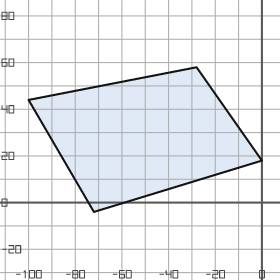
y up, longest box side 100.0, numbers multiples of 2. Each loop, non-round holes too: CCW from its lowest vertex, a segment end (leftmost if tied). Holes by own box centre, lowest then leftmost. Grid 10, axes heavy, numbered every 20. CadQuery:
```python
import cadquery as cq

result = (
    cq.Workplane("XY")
    .moveTo(-72.0, -4.0)
    .lineTo(0.0, 18.0)
    .lineTo(-28.0, 58.0)
    .lineTo(-100.0, 44.0)
    .close()
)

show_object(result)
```